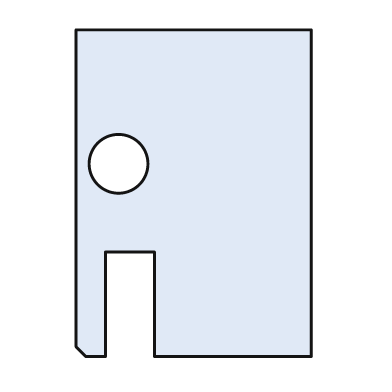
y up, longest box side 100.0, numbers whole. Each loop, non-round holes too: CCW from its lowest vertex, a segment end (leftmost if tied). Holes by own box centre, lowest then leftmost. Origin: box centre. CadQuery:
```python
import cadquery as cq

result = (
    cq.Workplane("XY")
    .moveTo(-33.0, -50.0)
    .lineTo(-27.0, -50.0)
    .lineTo(-27.0, -18.0)
    .lineTo(-12.0, -18.0)
    .lineTo(-12.0, -50.0)
    .lineTo(36.0, -50.0)
    .lineTo(36.0, 50.0)
    .lineTo(-36.0, 50.0)
    .lineTo(-36.0, -47.0)
    .close()
    .moveTo(-23.0, 9.0)
    .circle(9.0)
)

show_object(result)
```